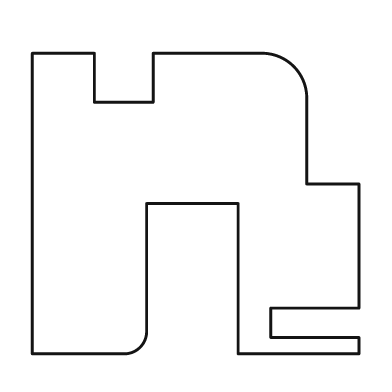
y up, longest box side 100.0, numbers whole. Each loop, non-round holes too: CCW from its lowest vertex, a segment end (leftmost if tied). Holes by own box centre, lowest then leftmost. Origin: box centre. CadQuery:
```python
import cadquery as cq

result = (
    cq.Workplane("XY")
    .moveTo(-50.0, -46.0)
    .lineTo(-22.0, -46.0)
    .threePointArc((-17.0, -44.0), (-15.0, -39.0))
    .lineTo(-15.0, 0.0)
    .lineTo(13.0, 0.0)
    .lineTo(13.0, -46.0)
    .lineTo(50.0, -46.0)
    .lineTo(50.0, -41.0)
    .lineTo(23.0, -41.0)
    .lineTo(23.0, -32.0)
    .lineTo(50.0, -32.0)
    .lineTo(50.0, 6.0)
    .lineTo(34.0, 6.0)
    .lineTo(34.0, 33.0)
    .threePointArc((30.0, 42.0), (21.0, 46.0))
    .lineTo(-13.0, 46.0)
    .lineTo(-13.0, 31.0)
    .lineTo(-31.0, 31.0)
    .lineTo(-31.0, 46.0)
    .lineTo(-50.0, 46.0)
    .close()
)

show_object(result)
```